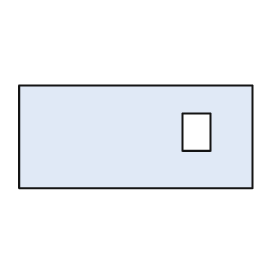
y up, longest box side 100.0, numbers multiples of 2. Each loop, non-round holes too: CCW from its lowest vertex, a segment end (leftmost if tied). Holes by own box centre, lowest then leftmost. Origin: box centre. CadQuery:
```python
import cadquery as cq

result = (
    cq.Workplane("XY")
    .moveTo(-50.0, -22.0)
    .lineTo(50.0, -22.0)
    .lineTo(50.0, 22.0)
    .lineTo(-50.0, 22.0)
    .close()
    .moveTo(20.0, -6.0)
    .lineTo(32.0, -6.0)
    .lineTo(32.0, 10.0)
    .lineTo(20.0, 10.0)
    .close()
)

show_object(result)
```